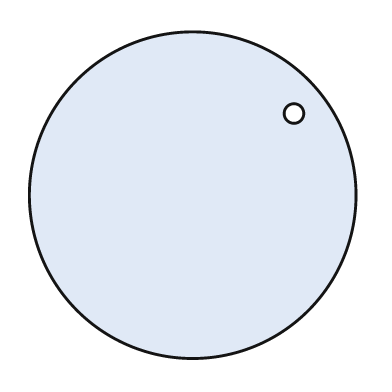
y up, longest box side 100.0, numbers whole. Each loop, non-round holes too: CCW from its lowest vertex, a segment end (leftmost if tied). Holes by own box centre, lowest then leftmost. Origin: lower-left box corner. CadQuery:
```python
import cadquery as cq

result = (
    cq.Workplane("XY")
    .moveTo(50.0, 50.0)
    .circle(50.0)
    .moveTo(81.0, 75.0)
    .circle(3.0)
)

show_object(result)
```